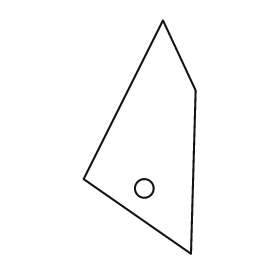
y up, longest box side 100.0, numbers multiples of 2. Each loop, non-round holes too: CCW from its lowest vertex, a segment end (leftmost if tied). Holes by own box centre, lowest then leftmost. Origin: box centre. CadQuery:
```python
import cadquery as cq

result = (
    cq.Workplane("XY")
    .moveTo(22.0, -50.0)
    .lineTo(24.0, 20.0)
    .lineTo(10.0, 50.0)
    .lineTo(-24.0, -18.0)
    .close()
    .moveTo(2.0, -22.0)
    .circle(4.0)
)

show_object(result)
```